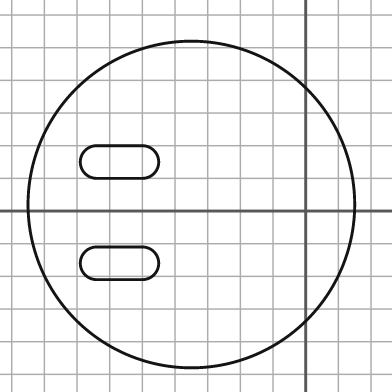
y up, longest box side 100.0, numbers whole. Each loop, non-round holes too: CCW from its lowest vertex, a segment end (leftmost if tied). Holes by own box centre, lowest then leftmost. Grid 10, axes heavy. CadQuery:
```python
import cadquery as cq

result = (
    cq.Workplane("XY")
    .moveTo(-35.0, 2.0)
    .circle(50.0)
    .moveTo(-64.0, -21.0)
    .lineTo(-50.0, -21.0)
    .threePointArc((-45.0, -16.0), (-50.0, -11.0))
    .lineTo(-64.0, -11.0)
    .threePointArc((-69.0, -16.0), (-64.0, -21.0))
    .close()
    .moveTo(-64.0, 10.0)
    .lineTo(-50.0, 10.0)
    .threePointArc((-45.0, 15.0), (-50.0, 20.0))
    .lineTo(-64.0, 20.0)
    .threePointArc((-69.0, 15.0), (-64.0, 10.0))
    .close()
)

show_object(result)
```